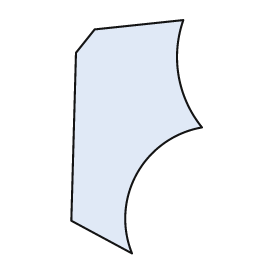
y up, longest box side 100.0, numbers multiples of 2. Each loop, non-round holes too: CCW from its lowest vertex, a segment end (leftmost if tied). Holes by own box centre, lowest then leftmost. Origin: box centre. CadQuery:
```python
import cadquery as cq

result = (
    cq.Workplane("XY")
    .moveTo(-2.0, -50.0)
    .threePointArc((0.0, -16.0), (28.0, 4.0))
    .threePointArc((18.0, 26.0), (20.0, 50.0))
    .lineTo(-18.0, 46.0)
    .lineTo(-26.0, 36.0)
    .lineTo(-28.0, -36.0)
    .close()
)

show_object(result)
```